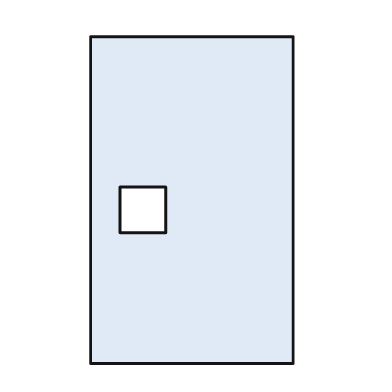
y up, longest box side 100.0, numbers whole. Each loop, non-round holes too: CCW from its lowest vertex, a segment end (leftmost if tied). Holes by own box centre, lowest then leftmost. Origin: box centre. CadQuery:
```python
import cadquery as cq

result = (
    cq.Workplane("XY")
    .moveTo(-31.0, -50.0)
    .lineTo(31.0, -50.0)
    .lineTo(31.0, 50.0)
    .lineTo(-31.0, 50.0)
    .close()
    .moveTo(-22.0, -10.0)
    .lineTo(-8.0, -10.0)
    .lineTo(-8.0, 4.0)
    .lineTo(-22.0, 4.0)
    .close()
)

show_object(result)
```